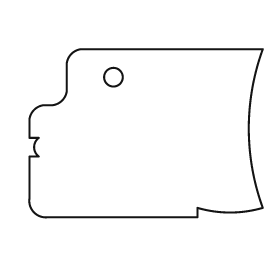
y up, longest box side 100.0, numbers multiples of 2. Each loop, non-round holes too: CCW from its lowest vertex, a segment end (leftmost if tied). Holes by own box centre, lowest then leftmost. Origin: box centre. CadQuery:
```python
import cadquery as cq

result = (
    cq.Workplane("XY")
    .moveTo(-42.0, -36.0)
    .lineTo(22.0, -36.0)
    .lineTo(22.0, -32.0)
    .threePointArc((36.0, -34.0), (50.0, -32.0))
    .threePointArc((44.0, 2.0), (50.0, 36.0))
    .lineTo(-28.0, 36.0)
    .threePointArc((-32.0, 34.0), (-34.0, 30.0))
    .lineTo(-34.0, 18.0)
    .threePointArc((-36.0, 14.0), (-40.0, 12.0))
    .lineTo(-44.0, 12.0)
    .threePointArc((-48.0, 10.0), (-50.0, 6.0))
    .lineTo(-50.0, -2.0)
    .lineTo(-46.0, -2.0)
    .threePointArc((-48.0, -6.0), (-46.0, -10.0))
    .lineTo(-50.0, -10.0)
    .lineTo(-50.0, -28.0)
    .threePointArc((-48.0, -34.0), (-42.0, -36.0))
    .close()
    .moveTo(-14.0, 24.0)
    .circle(4.0)
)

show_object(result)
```